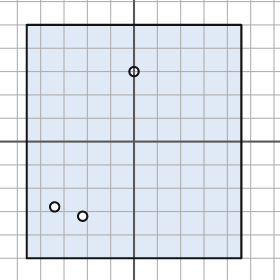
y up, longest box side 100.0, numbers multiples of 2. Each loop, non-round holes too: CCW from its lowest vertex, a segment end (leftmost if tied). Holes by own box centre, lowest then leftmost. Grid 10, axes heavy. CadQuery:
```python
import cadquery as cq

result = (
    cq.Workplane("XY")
    .moveTo(-46.0, -50.0)
    .lineTo(46.0, -50.0)
    .lineTo(46.0, 50.0)
    .lineTo(-46.0, 50.0)
    .close()
    .moveTo(-22.0, -32.0)
    .circle(2.0)
    .moveTo(-34.0, -28.0)
    .circle(2.0)
    .moveTo(0.0, 30.0)
    .circle(2.0)
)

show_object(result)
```